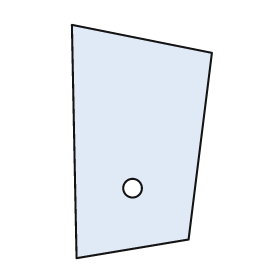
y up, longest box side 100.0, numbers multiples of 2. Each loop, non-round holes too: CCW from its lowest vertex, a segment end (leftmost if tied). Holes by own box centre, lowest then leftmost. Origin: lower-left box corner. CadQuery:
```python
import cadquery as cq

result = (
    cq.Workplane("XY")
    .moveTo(2.0, 0.0)
    .lineTo(50.0, 8.0)
    .lineTo(60.0, 88.0)
    .lineTo(0.0, 100.0)
    .close()
    .moveTo(26.0, 30.0)
    .circle(4.0)
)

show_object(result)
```